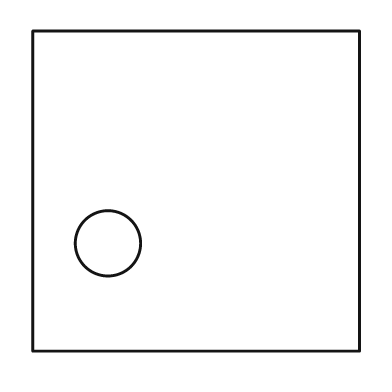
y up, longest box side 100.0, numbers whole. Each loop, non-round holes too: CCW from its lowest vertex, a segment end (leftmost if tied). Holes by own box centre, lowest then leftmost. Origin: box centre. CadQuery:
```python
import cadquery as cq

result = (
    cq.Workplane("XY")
    .moveTo(-50.0, -49.0)
    .lineTo(50.0, -49.0)
    .lineTo(50.0, 49.0)
    .lineTo(-50.0, 49.0)
    .close()
    .moveTo(-27.0, -16.0)
    .circle(10.0)
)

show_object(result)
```